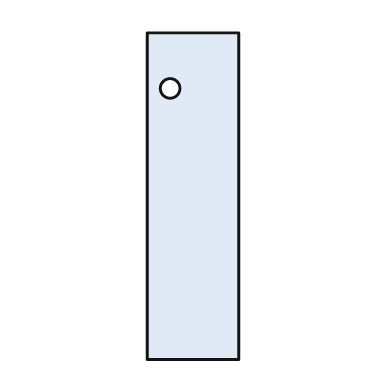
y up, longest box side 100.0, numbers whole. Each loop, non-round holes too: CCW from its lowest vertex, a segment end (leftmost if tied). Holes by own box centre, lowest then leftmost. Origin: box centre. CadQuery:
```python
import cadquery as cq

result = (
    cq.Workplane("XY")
    .moveTo(-14.0, -50.0)
    .lineTo(14.0, -50.0)
    .lineTo(14.0, 50.0)
    .lineTo(-14.0, 50.0)
    .close()
    .moveTo(-7.0, 33.0)
    .circle(3.0)
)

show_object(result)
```